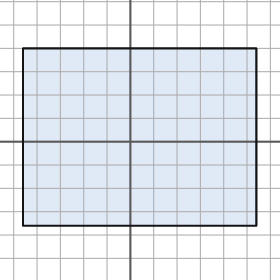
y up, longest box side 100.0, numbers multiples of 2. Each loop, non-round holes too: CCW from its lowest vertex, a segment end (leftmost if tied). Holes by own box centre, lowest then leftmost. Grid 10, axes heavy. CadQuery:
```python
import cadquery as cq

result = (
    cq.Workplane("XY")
    .moveTo(-46.0, -36.0)
    .lineTo(54.0, -36.0)
    .lineTo(54.0, 40.0)
    .lineTo(-46.0, 40.0)
    .close()
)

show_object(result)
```